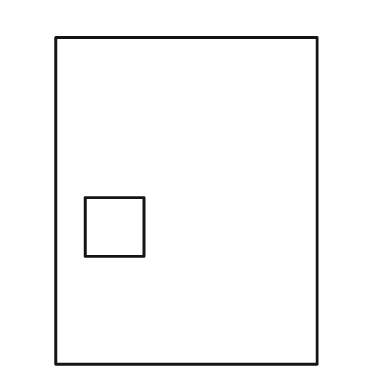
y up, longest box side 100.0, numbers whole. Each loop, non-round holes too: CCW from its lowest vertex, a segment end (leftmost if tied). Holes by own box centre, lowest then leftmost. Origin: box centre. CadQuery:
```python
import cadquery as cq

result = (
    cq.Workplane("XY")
    .moveTo(-40.0, -50.0)
    .lineTo(40.0, -50.0)
    .lineTo(40.0, 50.0)
    .lineTo(-40.0, 50.0)
    .close()
    .moveTo(-31.0, -17.0)
    .lineTo(-13.0, -17.0)
    .lineTo(-13.0, 1.0)
    .lineTo(-31.0, 1.0)
    .close()
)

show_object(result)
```